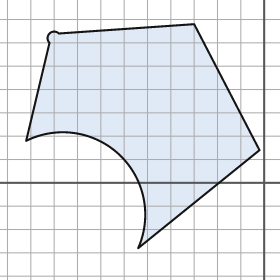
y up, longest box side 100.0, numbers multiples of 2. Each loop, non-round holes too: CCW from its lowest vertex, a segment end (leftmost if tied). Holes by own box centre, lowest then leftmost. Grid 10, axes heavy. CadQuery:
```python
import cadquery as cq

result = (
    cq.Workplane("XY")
    .moveTo(-54.0, -28.0)
    .lineTo(-2.0, 14.0)
    .lineTo(-30.0, 68.0)
    .lineTo(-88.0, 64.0)
    .threePointArc((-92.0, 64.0), (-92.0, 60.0))
    .lineTo(-102.0, 18.0)
    .threePointArc((-62.0, 12.0), (-54.0, -28.0))
    .close()
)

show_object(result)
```